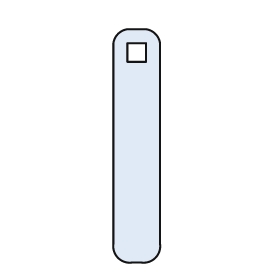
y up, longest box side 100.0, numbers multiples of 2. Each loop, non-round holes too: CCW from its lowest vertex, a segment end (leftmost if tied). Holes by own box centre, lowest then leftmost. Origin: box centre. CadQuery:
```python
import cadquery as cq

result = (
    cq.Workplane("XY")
    .moveTo(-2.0, -50.0)
    .lineTo(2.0, -50.0)
    .threePointArc((8.0, -48.0), (10.0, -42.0))
    .lineTo(10.0, 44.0)
    .threePointArc((8.0, 48.0), (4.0, 50.0))
    .lineTo(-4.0, 50.0)
    .threePointArc((-8.0, 48.0), (-10.0, 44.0))
    .lineTo(-10.0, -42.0)
    .threePointArc((-8.0, -48.0), (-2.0, -50.0))
    .close()
    .moveTo(-4.0, 36.0)
    .lineTo(4.0, 36.0)
    .lineTo(4.0, 44.0)
    .lineTo(-4.0, 44.0)
    .close()
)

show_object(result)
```